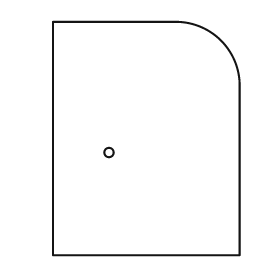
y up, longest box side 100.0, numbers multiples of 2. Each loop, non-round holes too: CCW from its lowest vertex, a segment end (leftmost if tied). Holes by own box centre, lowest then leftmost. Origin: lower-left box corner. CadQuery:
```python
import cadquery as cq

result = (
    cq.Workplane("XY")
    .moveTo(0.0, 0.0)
    .lineTo(80.0, 0.0)
    .lineTo(80.0, 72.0)
    .threePointArc((72.0, 92.0), (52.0, 100.0))
    .lineTo(0.0, 100.0)
    .close()
    .moveTo(24.0, 44.0)
    .circle(2.0)
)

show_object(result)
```